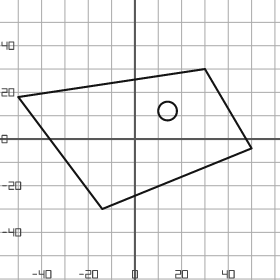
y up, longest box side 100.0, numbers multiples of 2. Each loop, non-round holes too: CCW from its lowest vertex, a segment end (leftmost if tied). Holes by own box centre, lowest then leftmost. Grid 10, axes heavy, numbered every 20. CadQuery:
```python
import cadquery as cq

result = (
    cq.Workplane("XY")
    .moveTo(-14.0, -30.0)
    .lineTo(50.0, -4.0)
    .lineTo(30.0, 30.0)
    .lineTo(-50.0, 18.0)
    .close()
    .moveTo(14.0, 12.0)
    .circle(4.0)
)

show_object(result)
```